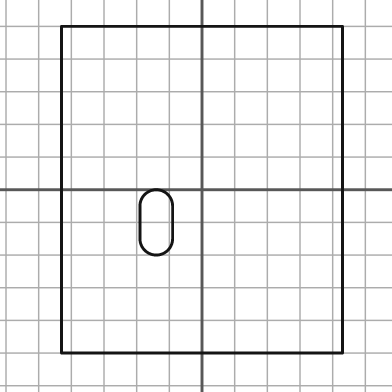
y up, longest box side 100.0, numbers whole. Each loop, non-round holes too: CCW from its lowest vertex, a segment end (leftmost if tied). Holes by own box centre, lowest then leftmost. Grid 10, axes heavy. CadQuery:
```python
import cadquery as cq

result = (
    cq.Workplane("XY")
    .moveTo(-43.0, -50.0)
    .lineTo(43.0, -50.0)
    .lineTo(43.0, 50.0)
    .lineTo(-43.0, 50.0)
    .close()
    .moveTo(-19.0, -15.0)
    .threePointArc((-14.0, -20.0), (-9.0, -15.0))
    .lineTo(-9.0, -5.0)
    .threePointArc((-14.0, 0.0), (-19.0, -5.0))
    .close()
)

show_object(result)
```